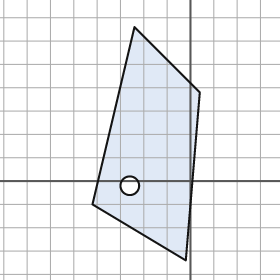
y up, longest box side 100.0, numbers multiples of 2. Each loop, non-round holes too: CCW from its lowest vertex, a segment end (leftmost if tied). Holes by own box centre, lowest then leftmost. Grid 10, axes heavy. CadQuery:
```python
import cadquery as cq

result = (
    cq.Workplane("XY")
    .moveTo(-2.0, -34.0)
    .lineTo(4.0, 38.0)
    .lineTo(-24.0, 66.0)
    .lineTo(-42.0, -10.0)
    .close()
    .moveTo(-26.0, -2.0)
    .circle(4.0)
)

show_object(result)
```